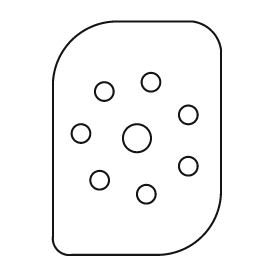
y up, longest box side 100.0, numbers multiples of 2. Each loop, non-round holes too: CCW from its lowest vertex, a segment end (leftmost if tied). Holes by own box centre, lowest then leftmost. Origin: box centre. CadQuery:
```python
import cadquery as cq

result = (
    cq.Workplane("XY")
    .moveTo(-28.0, -50.0)
    .lineTo(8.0, -50.0)
    .threePointArc((28.0, -42.0), (36.0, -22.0))
    .lineTo(36.0, 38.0)
    .threePointArc((32.0, 46.0), (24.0, 50.0))
    .lineTo(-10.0, 50.0)
    .threePointArc((-28.0, 42.0), (-36.0, 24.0))
    .lineTo(-36.0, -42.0)
    .threePointArc((-34.0, -48.0), (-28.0, -50.0))
    .close()
    .moveTo(4.0, -24.0)
    .circle(4.0)
    .moveTo(-16.0, -18.0)
    .circle(4.0)
    .moveTo(22.0, -12.0)
    .circle(4.0)
    .moveTo(0.0, 0.0)
    .circle(6.0)
    .moveTo(-24.0, 2.0)
    .circle(4.0)
    .moveTo(22.0, 10.0)
    .circle(4.0)
    .moveTo(-14.0, 20.0)
    .circle(4.0)
    .moveTo(6.0, 24.0)
    .circle(4.0)
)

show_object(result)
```